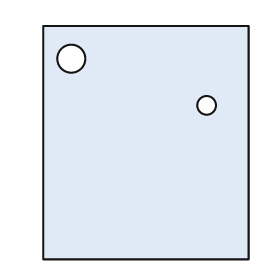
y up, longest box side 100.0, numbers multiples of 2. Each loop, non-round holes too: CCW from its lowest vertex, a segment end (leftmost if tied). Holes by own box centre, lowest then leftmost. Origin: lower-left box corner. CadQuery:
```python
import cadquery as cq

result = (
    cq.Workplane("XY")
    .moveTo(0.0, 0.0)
    .lineTo(88.0, 0.0)
    .lineTo(88.0, 100.0)
    .lineTo(0.0, 100.0)
    .close()
    .moveTo(70.0, 66.0)
    .circle(4.0)
    .moveTo(12.0, 86.0)
    .circle(6.0)
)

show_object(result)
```